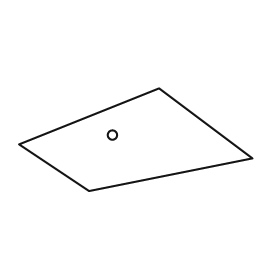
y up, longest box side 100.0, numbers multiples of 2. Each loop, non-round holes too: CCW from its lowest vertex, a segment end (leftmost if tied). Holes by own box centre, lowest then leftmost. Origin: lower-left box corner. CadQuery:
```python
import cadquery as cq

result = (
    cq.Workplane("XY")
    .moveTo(30.0, 0.0)
    .lineTo(100.0, 14.0)
    .lineTo(60.0, 44.0)
    .lineTo(0.0, 20.0)
    .close()
    .moveTo(40.0, 24.0)
    .circle(2.0)
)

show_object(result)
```